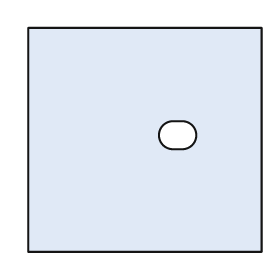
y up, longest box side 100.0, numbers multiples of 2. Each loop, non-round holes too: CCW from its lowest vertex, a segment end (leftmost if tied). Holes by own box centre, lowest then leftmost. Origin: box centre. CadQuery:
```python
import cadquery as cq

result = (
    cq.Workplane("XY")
    .moveTo(-50.0, -48.0)
    .lineTo(50.0, -48.0)
    .lineTo(50.0, 48.0)
    .lineTo(-50.0, 48.0)
    .close()
    .moveTo(12.0, -4.0)
    .lineTo(16.0, -4.0)
    .threePointArc((22.0, 2.0), (16.0, 8.0))
    .lineTo(12.0, 8.0)
    .threePointArc((6.0, 2.0), (12.0, -4.0))
    .close()
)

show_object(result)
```